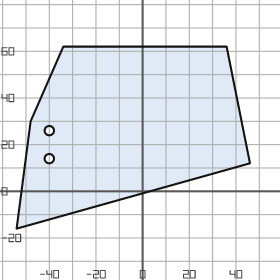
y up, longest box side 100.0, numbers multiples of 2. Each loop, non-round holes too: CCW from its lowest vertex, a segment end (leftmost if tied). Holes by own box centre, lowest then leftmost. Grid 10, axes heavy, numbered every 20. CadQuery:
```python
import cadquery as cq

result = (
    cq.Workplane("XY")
    .moveTo(-54.0, -16.0)
    .lineTo(46.0, 12.0)
    .lineTo(36.0, 62.0)
    .lineTo(-34.0, 62.0)
    .lineTo(-48.0, 30.0)
    .close()
    .moveTo(-40.0, 14.0)
    .circle(2.0)
    .moveTo(-40.0, 26.0)
    .circle(2.0)
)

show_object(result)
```